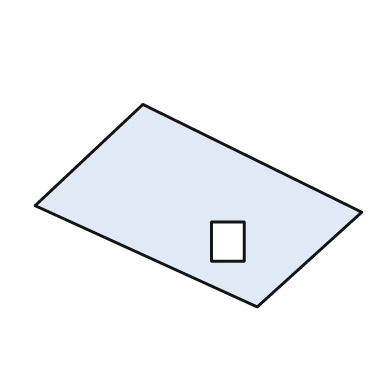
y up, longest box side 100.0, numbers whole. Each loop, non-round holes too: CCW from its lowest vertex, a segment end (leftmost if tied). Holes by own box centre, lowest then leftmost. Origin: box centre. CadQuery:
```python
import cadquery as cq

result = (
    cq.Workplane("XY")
    .moveTo(18.0, -31.0)
    .lineTo(50.0, -2.0)
    .lineTo(-17.0, 31.0)
    .lineTo(-50.0, 0.0)
    .close()
    .moveTo(4.0, -17.0)
    .lineTo(14.0, -17.0)
    .lineTo(14.0, -5.0)
    .lineTo(4.0, -5.0)
    .close()
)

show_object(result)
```